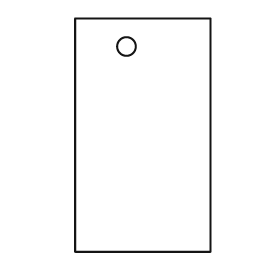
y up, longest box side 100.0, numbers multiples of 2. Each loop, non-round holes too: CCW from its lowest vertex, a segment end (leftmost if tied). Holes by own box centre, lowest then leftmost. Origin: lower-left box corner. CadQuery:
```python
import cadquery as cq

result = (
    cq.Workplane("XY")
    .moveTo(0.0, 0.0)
    .lineTo(58.0, 0.0)
    .lineTo(58.0, 100.0)
    .lineTo(0.0, 100.0)
    .close()
    .moveTo(22.0, 88.0)
    .circle(4.0)
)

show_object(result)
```